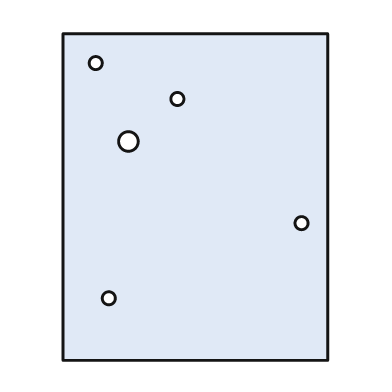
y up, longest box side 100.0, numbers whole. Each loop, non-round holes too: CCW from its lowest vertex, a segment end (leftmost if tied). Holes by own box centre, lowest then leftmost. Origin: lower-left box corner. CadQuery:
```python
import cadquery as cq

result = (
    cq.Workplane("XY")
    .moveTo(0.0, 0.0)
    .lineTo(81.0, 0.0)
    .lineTo(81.0, 100.0)
    .lineTo(0.0, 100.0)
    .close()
    .moveTo(14.0, 19.0)
    .circle(2.0)
    .moveTo(73.0, 42.0)
    .circle(2.0)
    .moveTo(20.0, 67.0)
    .circle(3.0)
    .moveTo(35.0, 80.0)
    .circle(2.0)
    .moveTo(10.0, 91.0)
    .circle(2.0)
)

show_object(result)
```